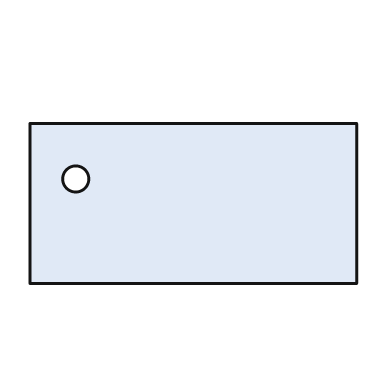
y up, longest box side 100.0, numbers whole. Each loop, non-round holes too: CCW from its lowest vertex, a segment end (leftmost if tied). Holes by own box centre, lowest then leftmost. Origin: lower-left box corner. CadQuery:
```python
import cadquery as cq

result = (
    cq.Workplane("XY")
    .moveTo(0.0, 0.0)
    .lineTo(100.0, 0.0)
    .lineTo(100.0, 49.0)
    .lineTo(0.0, 49.0)
    .close()
    .moveTo(14.0, 32.0)
    .circle(4.0)
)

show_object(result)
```